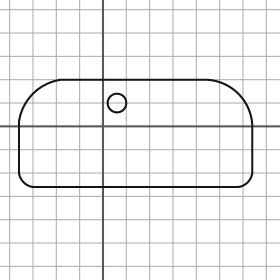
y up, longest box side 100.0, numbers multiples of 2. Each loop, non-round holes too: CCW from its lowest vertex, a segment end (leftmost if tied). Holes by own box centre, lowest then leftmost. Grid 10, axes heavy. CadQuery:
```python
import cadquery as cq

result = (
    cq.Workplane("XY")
    .moveTo(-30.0, -26.0)
    .lineTo(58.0, -26.0)
    .threePointArc((62.0, -24.0), (64.0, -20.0))
    .lineTo(64.0, 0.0)
    .threePointArc((58.0, 14.0), (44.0, 20.0))
    .lineTo(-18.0, 20.0)
    .threePointArc((-30.0, 14.0), (-36.0, 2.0))
    .lineTo(-36.0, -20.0)
    .threePointArc((-34.0, -24.0), (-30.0, -26.0))
    .close()
    .moveTo(6.0, 10.0)
    .circle(4.0)
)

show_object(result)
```